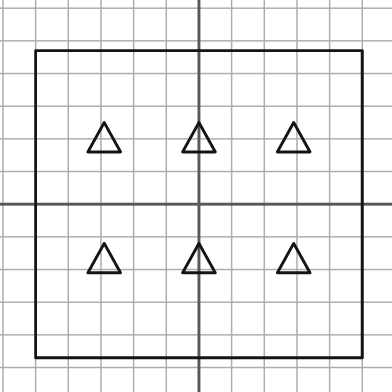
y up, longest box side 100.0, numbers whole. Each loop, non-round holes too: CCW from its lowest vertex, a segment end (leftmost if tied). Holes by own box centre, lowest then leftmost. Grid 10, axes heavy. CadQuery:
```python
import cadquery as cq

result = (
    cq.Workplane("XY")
    .moveTo(-50.0, -47.0)
    .lineTo(50.0, -47.0)
    .lineTo(50.0, 47.0)
    .lineTo(-50.0, 47.0)
    .close()
    .moveTo(-34.0, -21.0)
    .lineTo(-24.0, -21.0)
    .lineTo(-29.0, -12.0)
    .close()
    .moveTo(-5.0, -21.0)
    .lineTo(5.0, -21.0)
    .lineTo(0.0, -12.0)
    .close()
    .moveTo(24.0, -21.0)
    .lineTo(34.0, -21.0)
    .lineTo(29.0, -12.0)
    .close()
    .moveTo(-34.0, 16.0)
    .lineTo(-24.0, 16.0)
    .lineTo(-29.0, 25.0)
    .close()
    .moveTo(-5.0, 16.0)
    .lineTo(5.0, 16.0)
    .lineTo(0.0, 25.0)
    .close()
    .moveTo(24.0, 16.0)
    .lineTo(34.0, 16.0)
    .lineTo(29.0, 25.0)
    .close()
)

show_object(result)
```